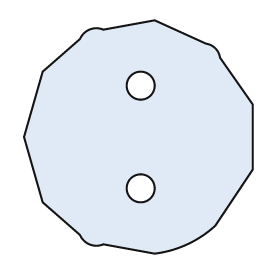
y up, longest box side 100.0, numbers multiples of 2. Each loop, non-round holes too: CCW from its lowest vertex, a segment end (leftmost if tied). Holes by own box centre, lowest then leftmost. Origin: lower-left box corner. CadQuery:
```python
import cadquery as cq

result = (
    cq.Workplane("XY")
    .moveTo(56.0, 0.0)
    .threePointArc((70.0, 4.0), (82.0, 12.0))
    .lineTo(98.0, 36.0)
    .lineTo(98.0, 64.0)
    .lineTo(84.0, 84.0)
    .threePointArc((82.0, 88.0), (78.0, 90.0))
    .lineTo(56.0, 100.0)
    .lineTo(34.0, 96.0)
    .threePointArc((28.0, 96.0), (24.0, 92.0))
    .lineTo(8.0, 78.0)
    .lineTo(0.0, 50.0)
    .lineTo(8.0, 22.0)
    .lineTo(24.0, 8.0)
    .threePointArc((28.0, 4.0), (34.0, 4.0))
    .close()
    .moveTo(50.0, 28.0)
    .circle(6.0)
    .moveTo(50.0, 72.0)
    .circle(6.0)
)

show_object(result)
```